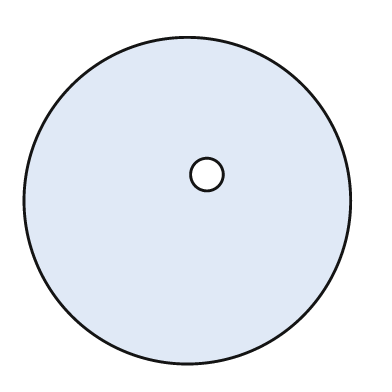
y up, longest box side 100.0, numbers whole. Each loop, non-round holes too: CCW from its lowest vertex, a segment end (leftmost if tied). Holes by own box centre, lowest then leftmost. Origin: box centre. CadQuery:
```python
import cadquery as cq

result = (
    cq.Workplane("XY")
    .moveTo(0.0, 0.0)
    .circle(50.0)
    .moveTo(6.0, 8.0)
    .circle(5.0)
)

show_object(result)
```